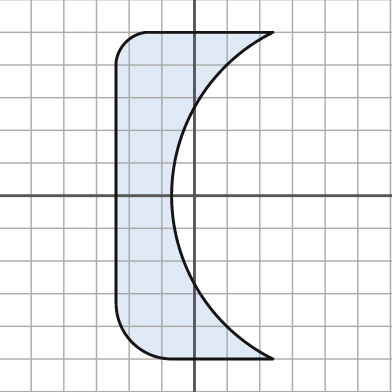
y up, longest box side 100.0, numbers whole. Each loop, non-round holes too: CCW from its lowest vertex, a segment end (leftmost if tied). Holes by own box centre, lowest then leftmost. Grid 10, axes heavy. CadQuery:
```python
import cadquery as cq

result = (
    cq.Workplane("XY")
    .moveTo(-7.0, -50.0)
    .lineTo(24.0, -50.0)
    .threePointArc((-7.0, 0.0), (24.0, 50.0))
    .lineTo(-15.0, 50.0)
    .threePointArc((-21.0, 47.0), (-24.0, 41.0))
    .lineTo(-24.0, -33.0)
    .threePointArc((-19.0, -45.0), (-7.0, -50.0))
    .close()
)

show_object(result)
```